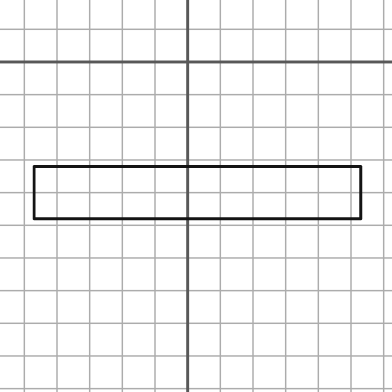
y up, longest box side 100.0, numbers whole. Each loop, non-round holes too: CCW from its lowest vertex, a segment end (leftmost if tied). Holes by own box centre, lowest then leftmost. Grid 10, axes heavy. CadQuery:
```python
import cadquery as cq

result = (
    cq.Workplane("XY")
    .moveTo(-47.0, -48.0)
    .lineTo(53.0, -48.0)
    .lineTo(53.0, -32.0)
    .lineTo(-47.0, -32.0)
    .close()
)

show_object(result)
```